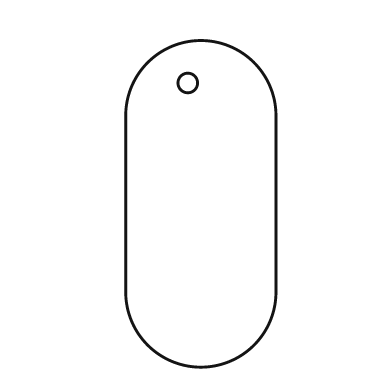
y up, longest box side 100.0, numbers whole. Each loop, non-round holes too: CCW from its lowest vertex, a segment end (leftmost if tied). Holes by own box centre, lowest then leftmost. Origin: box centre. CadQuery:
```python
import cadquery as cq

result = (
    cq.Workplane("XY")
    .moveTo(-23.0, -27.0)
    .threePointArc((0.0, -50.0), (23.0, -27.0))
    .lineTo(23.0, 27.0)
    .threePointArc((0.0, 50.0), (-23.0, 27.0))
    .close()
    .moveTo(-4.0, 37.0)
    .circle(3.0)
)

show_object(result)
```